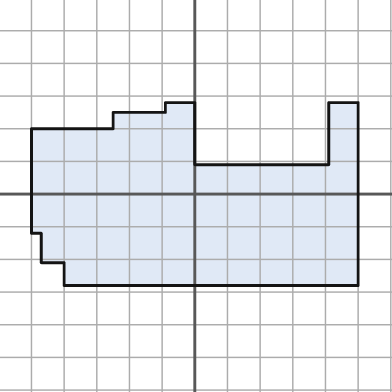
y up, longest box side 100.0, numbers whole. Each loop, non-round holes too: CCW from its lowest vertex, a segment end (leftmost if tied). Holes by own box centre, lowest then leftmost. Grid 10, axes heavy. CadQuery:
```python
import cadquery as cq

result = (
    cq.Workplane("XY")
    .moveTo(-40.0, -28.0)
    .lineTo(50.0, -28.0)
    .lineTo(50.0, 28.0)
    .lineTo(41.0, 28.0)
    .lineTo(41.0, 9.0)
    .lineTo(0.0, 9.0)
    .lineTo(0.0, 28.0)
    .lineTo(-9.0, 28.0)
    .lineTo(-9.0, 25.0)
    .lineTo(-25.0, 25.0)
    .lineTo(-25.0, 20.0)
    .lineTo(-50.0, 20.0)
    .lineTo(-50.0, -12.0)
    .lineTo(-47.0, -12.0)
    .lineTo(-47.0, -21.0)
    .lineTo(-40.0, -21.0)
    .close()
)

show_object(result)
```